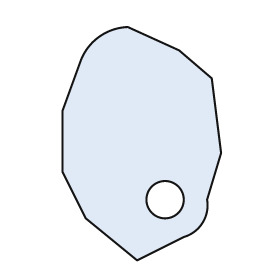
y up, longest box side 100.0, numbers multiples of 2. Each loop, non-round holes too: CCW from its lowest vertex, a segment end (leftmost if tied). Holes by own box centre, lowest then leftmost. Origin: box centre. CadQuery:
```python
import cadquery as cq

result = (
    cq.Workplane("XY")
    .moveTo(-2.0, -50.0)
    .lineTo(18.0, -40.0)
    .threePointArc((26.0, -34.0), (28.0, -24.0))
    .lineTo(34.0, -4.0)
    .lineTo(30.0, 28.0)
    .lineTo(16.0, 40.0)
    .lineTo(-6.0, 50.0)
    .threePointArc((-18.0, 46.0), (-26.0, 36.0))
    .lineTo(-34.0, 14.0)
    .lineTo(-34.0, -12.0)
    .lineTo(-24.0, -32.0)
    .close()
    .moveTo(10.0, -24.0)
    .circle(8.0)
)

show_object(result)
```